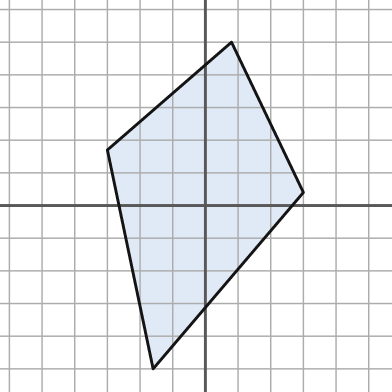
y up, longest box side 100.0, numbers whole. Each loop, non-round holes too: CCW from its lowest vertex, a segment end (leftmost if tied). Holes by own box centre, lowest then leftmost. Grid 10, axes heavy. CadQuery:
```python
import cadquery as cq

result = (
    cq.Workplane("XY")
    .moveTo(-16.0, -50.0)
    .lineTo(30.0, 4.0)
    .lineTo(8.0, 50.0)
    .lineTo(-30.0, 17.0)
    .close()
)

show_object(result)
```